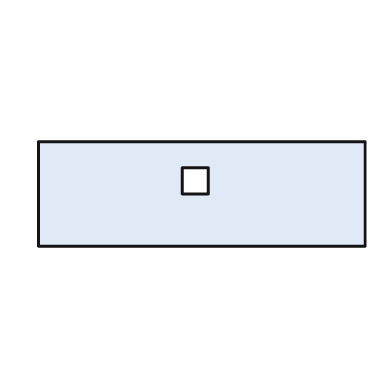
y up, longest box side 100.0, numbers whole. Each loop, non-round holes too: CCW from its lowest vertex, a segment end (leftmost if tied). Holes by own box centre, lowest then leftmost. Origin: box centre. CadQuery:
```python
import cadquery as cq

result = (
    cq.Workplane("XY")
    .moveTo(-50.0, -16.0)
    .lineTo(50.0, -16.0)
    .lineTo(50.0, 16.0)
    .lineTo(-50.0, 16.0)
    .close()
    .moveTo(-6.0, 0.0)
    .lineTo(2.0, 0.0)
    .lineTo(2.0, 8.0)
    .lineTo(-6.0, 8.0)
    .close()
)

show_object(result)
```